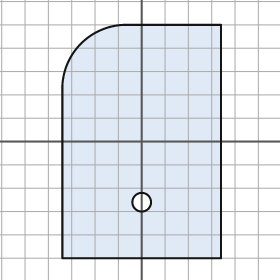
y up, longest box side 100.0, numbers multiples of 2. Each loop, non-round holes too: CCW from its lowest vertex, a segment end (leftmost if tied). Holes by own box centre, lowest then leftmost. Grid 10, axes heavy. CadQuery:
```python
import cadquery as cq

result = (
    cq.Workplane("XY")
    .moveTo(-34.0, -50.0)
    .lineTo(34.0, -50.0)
    .lineTo(34.0, 50.0)
    .lineTo(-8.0, 50.0)
    .threePointArc((-26.0, 42.0), (-34.0, 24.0))
    .close()
    .moveTo(0.0, -26.0)
    .circle(4.0)
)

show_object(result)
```